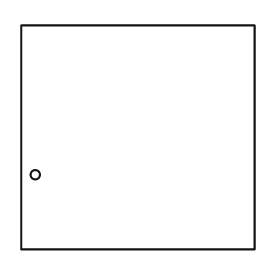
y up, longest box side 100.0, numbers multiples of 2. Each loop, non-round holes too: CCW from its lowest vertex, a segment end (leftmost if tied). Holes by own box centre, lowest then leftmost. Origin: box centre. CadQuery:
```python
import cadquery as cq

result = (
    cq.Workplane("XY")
    .moveTo(-50.0, -48.0)
    .lineTo(50.0, -48.0)
    .lineTo(50.0, 48.0)
    .lineTo(-50.0, 48.0)
    .close()
    .moveTo(-44.0, -16.0)
    .circle(2.0)
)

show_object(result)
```